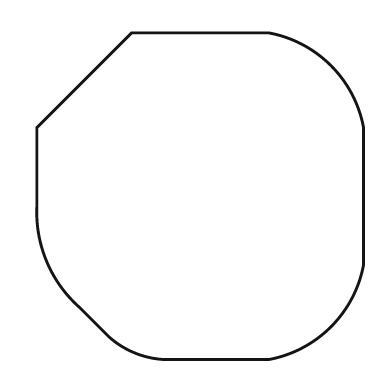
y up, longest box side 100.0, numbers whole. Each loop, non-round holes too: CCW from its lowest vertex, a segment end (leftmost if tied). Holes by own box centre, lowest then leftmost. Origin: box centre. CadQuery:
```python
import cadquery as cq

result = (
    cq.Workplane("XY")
    .moveTo(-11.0, -50.0)
    .lineTo(21.0, -50.0)
    .threePointArc((40.0, -40.0), (50.0, -21.0))
    .lineTo(50.0, 21.0)
    .threePointArc((40.0, 40.0), (21.0, 50.0))
    .lineTo(-21.0, 50.0)
    .lineTo(-50.0, 21.0)
    .lineTo(-50.0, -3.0)
    .threePointArc((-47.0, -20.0), (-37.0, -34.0))
    .lineTo(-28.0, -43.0)
    .threePointArc((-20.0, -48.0), (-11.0, -50.0))
    .close()
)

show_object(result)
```